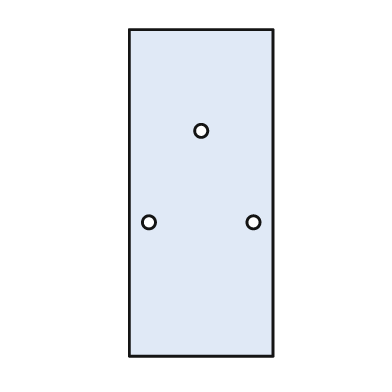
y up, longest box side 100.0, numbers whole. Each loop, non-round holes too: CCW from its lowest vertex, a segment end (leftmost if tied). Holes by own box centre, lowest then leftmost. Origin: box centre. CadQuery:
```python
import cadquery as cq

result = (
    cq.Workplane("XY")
    .moveTo(-22.0, -50.0)
    .lineTo(22.0, -50.0)
    .lineTo(22.0, 50.0)
    .lineTo(-22.0, 50.0)
    .close()
    .moveTo(-16.0, -9.0)
    .circle(2.0)
    .moveTo(16.0, -9.0)
    .circle(2.0)
    .moveTo(0.0, 19.0)
    .circle(2.0)
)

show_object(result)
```